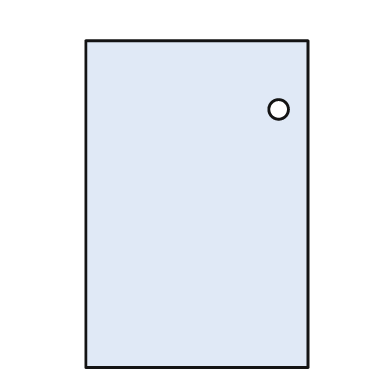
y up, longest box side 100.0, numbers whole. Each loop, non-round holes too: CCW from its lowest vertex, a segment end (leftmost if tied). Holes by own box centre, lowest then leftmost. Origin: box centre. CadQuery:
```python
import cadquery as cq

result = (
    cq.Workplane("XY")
    .moveTo(-34.0, -50.0)
    .lineTo(34.0, -50.0)
    .lineTo(34.0, 50.0)
    .lineTo(-34.0, 50.0)
    .close()
    .moveTo(25.0, 29.0)
    .circle(3.0)
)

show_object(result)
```